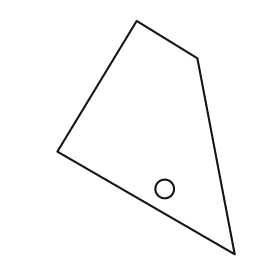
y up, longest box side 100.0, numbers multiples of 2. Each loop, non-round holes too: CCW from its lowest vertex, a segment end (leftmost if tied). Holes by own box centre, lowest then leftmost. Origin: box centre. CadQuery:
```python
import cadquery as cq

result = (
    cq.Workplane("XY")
    .moveTo(38.0, -50.0)
    .lineTo(22.0, 34.0)
    .lineTo(-4.0, 50.0)
    .lineTo(-38.0, -6.0)
    .close()
    .moveTo(8.0, -22.0)
    .circle(4.0)
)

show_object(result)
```